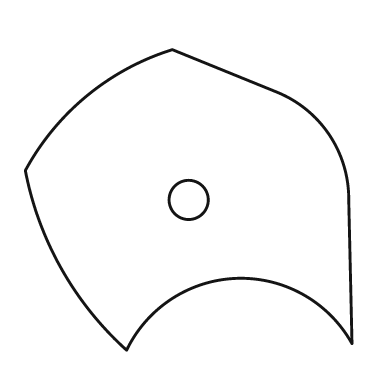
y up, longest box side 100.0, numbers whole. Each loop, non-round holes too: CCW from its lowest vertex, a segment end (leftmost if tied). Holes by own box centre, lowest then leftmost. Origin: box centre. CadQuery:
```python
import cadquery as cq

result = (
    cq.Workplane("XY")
    .moveTo(-19.0, -46.0)
    .threePointArc((15.0, -24.0), (50.0, -44.0))
    .lineTo(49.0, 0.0)
    .threePointArc((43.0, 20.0), (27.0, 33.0))
    .lineTo(-5.0, 46.0)
    .threePointArc((-31.0, 32.0), (-50.0, 9.0))
    .threePointArc((-39.0, -21.0), (-19.0, -46.0))
    .close()
    .moveTo(0.0, 0.0)
    .circle(6.0)
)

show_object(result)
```